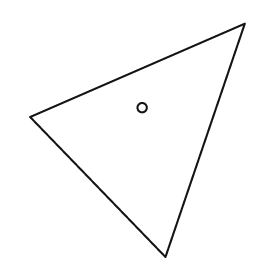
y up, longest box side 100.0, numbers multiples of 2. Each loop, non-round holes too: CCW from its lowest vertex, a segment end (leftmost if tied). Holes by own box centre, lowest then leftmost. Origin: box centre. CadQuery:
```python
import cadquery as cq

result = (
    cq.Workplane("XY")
    .moveTo(12.0, -50.0)
    .lineTo(46.0, 50.0)
    .lineTo(-46.0, 10.0)
    .close()
    .moveTo(2.0, 14.0)
    .circle(2.0)
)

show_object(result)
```